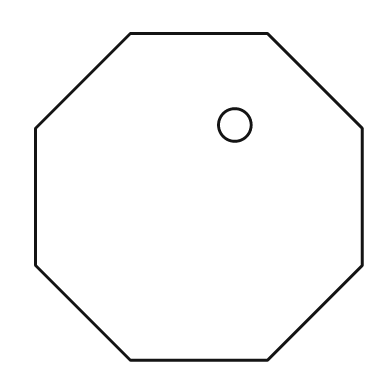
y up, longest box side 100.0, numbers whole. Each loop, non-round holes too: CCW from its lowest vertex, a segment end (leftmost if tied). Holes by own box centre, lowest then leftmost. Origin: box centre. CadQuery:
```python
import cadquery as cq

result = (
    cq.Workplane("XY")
    .moveTo(-21.0, -50.0)
    .lineTo(21.0, -50.0)
    .lineTo(50.0, -21.0)
    .lineTo(50.0, 21.0)
    .lineTo(21.0, 50.0)
    .lineTo(-21.0, 50.0)
    .lineTo(-50.0, 21.0)
    .lineTo(-50.0, -21.0)
    .close()
    .moveTo(11.0, 22.0)
    .circle(5.0)
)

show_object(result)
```